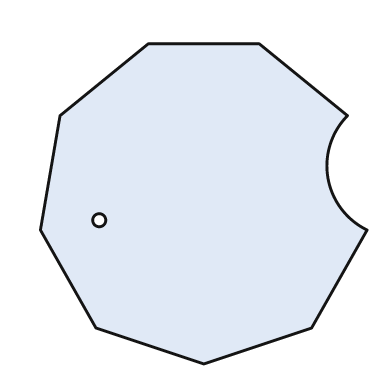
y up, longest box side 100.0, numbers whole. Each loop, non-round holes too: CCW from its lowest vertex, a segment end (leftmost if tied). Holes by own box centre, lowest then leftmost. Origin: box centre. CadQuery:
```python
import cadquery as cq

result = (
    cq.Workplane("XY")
    .moveTo(0.0, -49.0)
    .lineTo(33.0, -38.0)
    .lineTo(50.0, -8.0)
    .threePointArc((38.0, 8.0), (44.0, 27.0))
    .lineTo(17.0, 49.0)
    .lineTo(-17.0, 49.0)
    .lineTo(-44.0, 27.0)
    .lineTo(-50.0, -8.0)
    .lineTo(-33.0, -38.0)
    .close()
    .moveTo(-32.0, -5.0)
    .circle(2.0)
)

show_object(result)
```